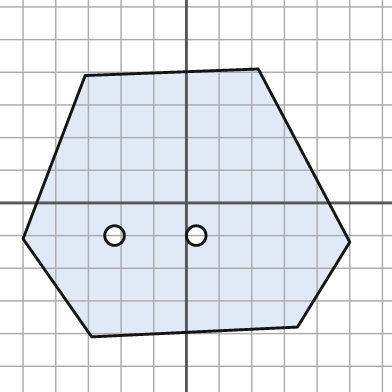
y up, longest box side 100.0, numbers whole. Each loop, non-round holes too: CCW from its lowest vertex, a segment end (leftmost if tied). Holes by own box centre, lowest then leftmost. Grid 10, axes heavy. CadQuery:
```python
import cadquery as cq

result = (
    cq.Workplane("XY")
    .moveTo(-29.0, -41.0)
    .lineTo(34.0, -38.0)
    .lineTo(50.0, -12.0)
    .lineTo(22.0, 41.0)
    .lineTo(-31.0, 39.0)
    .lineTo(-50.0, -11.0)
    .close()
    .moveTo(-22.0, -10.0)
    .circle(3.0)
    .moveTo(3.0, -10.0)
    .circle(3.0)
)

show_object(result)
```